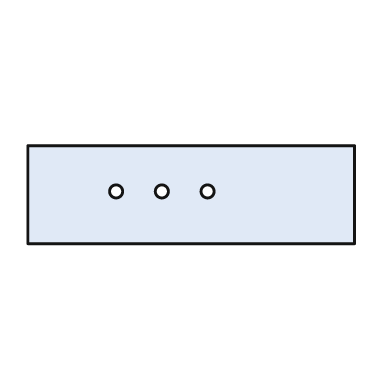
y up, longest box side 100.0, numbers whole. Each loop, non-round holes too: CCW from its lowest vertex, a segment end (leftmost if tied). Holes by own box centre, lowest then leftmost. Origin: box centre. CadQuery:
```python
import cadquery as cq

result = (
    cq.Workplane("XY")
    .moveTo(-50.0, -15.0)
    .lineTo(50.0, -15.0)
    .lineTo(50.0, 15.0)
    .lineTo(-50.0, 15.0)
    .close()
    .moveTo(-23.0, 1.0)
    .circle(2.0)
    .moveTo(-9.0, 1.0)
    .circle(2.0)
    .moveTo(5.0, 1.0)
    .circle(2.0)
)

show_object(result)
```